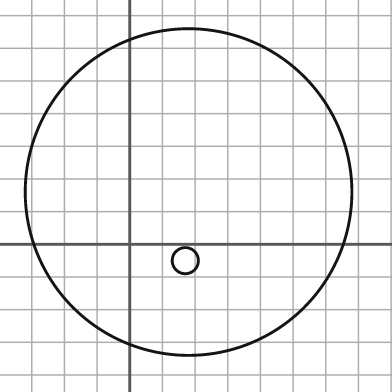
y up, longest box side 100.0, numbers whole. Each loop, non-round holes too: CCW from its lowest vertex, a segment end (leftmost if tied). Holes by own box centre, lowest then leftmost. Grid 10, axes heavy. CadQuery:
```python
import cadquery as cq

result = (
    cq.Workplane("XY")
    .moveTo(18.0, 16.0)
    .circle(50.0)
    .moveTo(17.0, -5.0)
    .circle(4.0)
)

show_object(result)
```